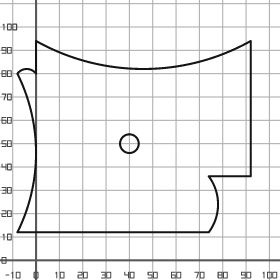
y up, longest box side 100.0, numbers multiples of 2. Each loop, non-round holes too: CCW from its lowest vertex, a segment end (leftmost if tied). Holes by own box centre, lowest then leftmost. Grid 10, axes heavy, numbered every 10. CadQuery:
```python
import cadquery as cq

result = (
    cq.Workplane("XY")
    .moveTo(-8.0, 12.0)
    .lineTo(74.0, 12.0)
    .threePointArc((78.0, 24.0), (74.0, 36.0))
    .lineTo(92.0, 36.0)
    .lineTo(92.0, 94.0)
    .threePointArc((46.0, 82.0), (0.0, 94.0))
    .lineTo(0.0, 80.0)
    .threePointArc((-4.0, 82.0), (-8.0, 80.0))
    .threePointArc((0.0, 46.0), (-8.0, 12.0))
    .close()
    .moveTo(40.0, 50.0)
    .circle(4.0)
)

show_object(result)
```